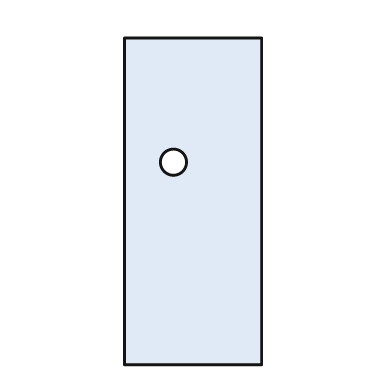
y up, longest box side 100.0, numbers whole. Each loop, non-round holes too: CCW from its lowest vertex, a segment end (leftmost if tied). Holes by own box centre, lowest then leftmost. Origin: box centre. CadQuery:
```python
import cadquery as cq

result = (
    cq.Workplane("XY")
    .moveTo(-21.0, -50.0)
    .lineTo(21.0, -50.0)
    .lineTo(21.0, 50.0)
    .lineTo(-21.0, 50.0)
    .close()
    .moveTo(-6.0, 12.0)
    .circle(4.0)
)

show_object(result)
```